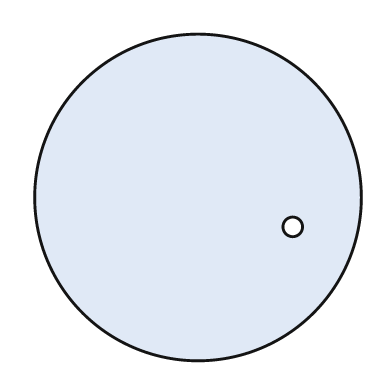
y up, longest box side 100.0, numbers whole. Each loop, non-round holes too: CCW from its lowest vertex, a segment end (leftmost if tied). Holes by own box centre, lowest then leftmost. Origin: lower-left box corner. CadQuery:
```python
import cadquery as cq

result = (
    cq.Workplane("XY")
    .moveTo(50.0, 50.0)
    .circle(50.0)
    .moveTo(79.0, 41.0)
    .circle(3.0)
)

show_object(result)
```